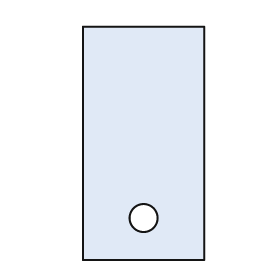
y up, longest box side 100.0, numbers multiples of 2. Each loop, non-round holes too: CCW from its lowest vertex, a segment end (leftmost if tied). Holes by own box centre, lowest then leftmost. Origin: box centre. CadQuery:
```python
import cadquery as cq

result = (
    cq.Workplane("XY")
    .moveTo(-26.0, -50.0)
    .lineTo(26.0, -50.0)
    .lineTo(26.0, 50.0)
    .lineTo(-26.0, 50.0)
    .close()
    .moveTo(0.0, -32.0)
    .circle(6.0)
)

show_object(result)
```